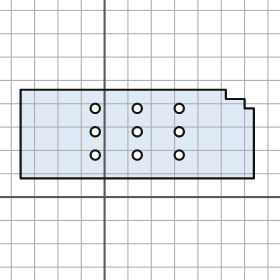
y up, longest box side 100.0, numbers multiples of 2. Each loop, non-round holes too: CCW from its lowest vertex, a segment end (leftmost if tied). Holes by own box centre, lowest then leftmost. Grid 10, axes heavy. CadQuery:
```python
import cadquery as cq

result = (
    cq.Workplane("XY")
    .moveTo(-36.0, 8.0)
    .lineTo(64.0, 8.0)
    .lineTo(64.0, 38.0)
    .lineTo(60.0, 38.0)
    .lineTo(60.0, 42.0)
    .lineTo(52.0, 42.0)
    .lineTo(52.0, 46.0)
    .lineTo(-36.0, 46.0)
    .close()
    .moveTo(-4.0, 18.0)
    .circle(2.0)
    .moveTo(14.0, 18.0)
    .circle(2.0)
    .moveTo(32.0, 18.0)
    .circle(2.0)
    .moveTo(-4.0, 28.0)
    .circle(2.0)
    .moveTo(14.0, 28.0)
    .circle(2.0)
    .moveTo(32.0, 28.0)
    .circle(2.0)
    .moveTo(-4.0, 38.0)
    .circle(2.0)
    .moveTo(14.0, 38.0)
    .circle(2.0)
    .moveTo(32.0, 38.0)
    .circle(2.0)
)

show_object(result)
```